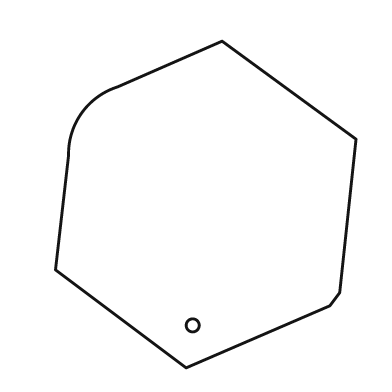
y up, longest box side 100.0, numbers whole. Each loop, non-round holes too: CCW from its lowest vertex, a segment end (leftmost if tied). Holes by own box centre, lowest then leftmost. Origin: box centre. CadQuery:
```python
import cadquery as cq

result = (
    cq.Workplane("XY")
    .moveTo(-6.0, -50.0)
    .lineTo(38.0, -31.0)
    .lineTo(41.0, -27.0)
    .lineTo(46.0, 20.0)
    .lineTo(5.0, 50.0)
    .lineTo(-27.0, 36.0)
    .threePointArc((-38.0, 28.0), (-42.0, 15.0))
    .lineTo(-46.0, -20.0)
    .close()
    .moveTo(-4.0, -37.0)
    .circle(2.0)
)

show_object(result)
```